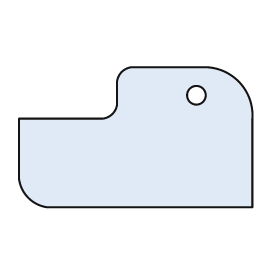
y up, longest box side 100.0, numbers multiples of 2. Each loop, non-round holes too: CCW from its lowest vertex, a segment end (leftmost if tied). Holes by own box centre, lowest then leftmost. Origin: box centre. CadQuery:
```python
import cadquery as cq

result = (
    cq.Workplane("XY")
    .moveTo(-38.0, -30.0)
    .lineTo(50.0, -30.0)
    .lineTo(50.0, 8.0)
    .threePointArc((44.0, 24.0), (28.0, 30.0))
    .lineTo(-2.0, 30.0)
    .threePointArc((-6.0, 28.0), (-8.0, 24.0))
    .lineTo(-8.0, 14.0)
    .threePointArc((-10.0, 10.0), (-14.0, 8.0))
    .lineTo(-50.0, 8.0)
    .lineTo(-50.0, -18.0)
    .threePointArc((-46.0, -26.0), (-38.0, -30.0))
    .close()
    .moveTo(26.0, 18.0)
    .circle(4.0)
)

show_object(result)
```